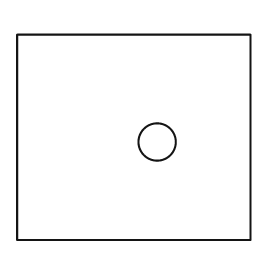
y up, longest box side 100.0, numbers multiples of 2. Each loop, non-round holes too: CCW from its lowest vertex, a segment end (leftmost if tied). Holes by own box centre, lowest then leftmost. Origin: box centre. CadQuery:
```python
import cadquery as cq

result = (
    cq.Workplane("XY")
    .moveTo(-50.0, -44.0)
    .lineTo(50.0, -44.0)
    .lineTo(50.0, 44.0)
    .lineTo(-50.0, 44.0)
    .close()
    .moveTo(10.0, -2.0)
    .circle(8.0)
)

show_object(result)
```